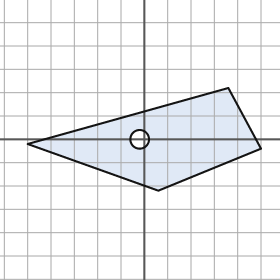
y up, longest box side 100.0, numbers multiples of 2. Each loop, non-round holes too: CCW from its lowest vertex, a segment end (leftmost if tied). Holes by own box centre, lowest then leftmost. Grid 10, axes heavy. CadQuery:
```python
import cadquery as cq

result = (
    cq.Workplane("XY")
    .moveTo(6.0, -22.0)
    .lineTo(50.0, -4.0)
    .lineTo(36.0, 22.0)
    .lineTo(-50.0, -2.0)
    .close()
    .moveTo(-2.0, 0.0)
    .circle(4.0)
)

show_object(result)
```